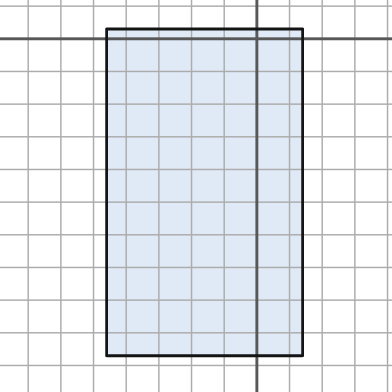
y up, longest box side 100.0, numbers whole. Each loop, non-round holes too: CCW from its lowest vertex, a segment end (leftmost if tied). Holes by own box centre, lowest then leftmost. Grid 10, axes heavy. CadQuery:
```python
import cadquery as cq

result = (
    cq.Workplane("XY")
    .moveTo(-46.0, -97.0)
    .lineTo(14.0, -97.0)
    .lineTo(14.0, 3.0)
    .lineTo(-46.0, 3.0)
    .close()
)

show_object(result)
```